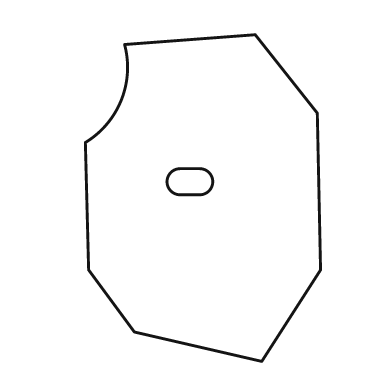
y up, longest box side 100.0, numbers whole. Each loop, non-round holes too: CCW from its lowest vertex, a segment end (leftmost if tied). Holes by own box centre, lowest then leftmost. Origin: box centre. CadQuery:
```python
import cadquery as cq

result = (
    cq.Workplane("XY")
    .moveTo(18.0, -50.0)
    .lineTo(36.0, -22.0)
    .lineTo(35.0, 26.0)
    .lineTo(16.0, 50.0)
    .lineTo(-24.0, 47.0)
    .threePointArc((-25.0, 30.0), (-36.0, 17.0))
    .lineTo(-35.0, -22.0)
    .lineTo(-21.0, -41.0)
    .close()
    .moveTo(-7.0, 1.0)
    .lineTo(-1.0, 1.0)
    .threePointArc((3.0, 5.0), (-1.0, 9.0))
    .lineTo(-7.0, 9.0)
    .threePointArc((-11.0, 5.0), (-7.0, 1.0))
    .close()
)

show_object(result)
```